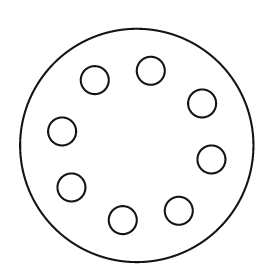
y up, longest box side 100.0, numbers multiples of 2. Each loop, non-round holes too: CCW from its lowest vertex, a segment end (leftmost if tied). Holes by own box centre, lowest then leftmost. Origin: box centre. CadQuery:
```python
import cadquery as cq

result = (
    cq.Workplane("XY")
    .moveTo(0.0, 0.0)
    .circle(50.0)
    .moveTo(-6.0, -32.0)
    .circle(6.0)
    .moveTo(18.0, -28.0)
    .circle(6.0)
    .moveTo(-28.0, -18.0)
    .circle(6.0)
    .moveTo(32.0, -6.0)
    .circle(6.0)
    .moveTo(-32.0, 6.0)
    .circle(6.0)
    .moveTo(28.0, 18.0)
    .circle(6.0)
    .moveTo(-18.0, 28.0)
    .circle(6.0)
    .moveTo(6.0, 32.0)
    .circle(6.0)
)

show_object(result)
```